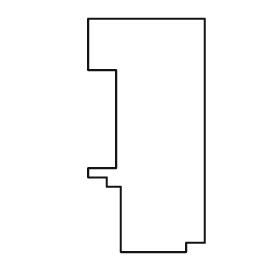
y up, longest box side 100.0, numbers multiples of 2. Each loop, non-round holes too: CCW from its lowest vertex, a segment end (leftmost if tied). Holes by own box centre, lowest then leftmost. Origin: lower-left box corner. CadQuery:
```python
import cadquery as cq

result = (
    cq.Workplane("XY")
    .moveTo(14.0, 0.0)
    .lineTo(42.0, 0.0)
    .lineTo(42.0, 4.0)
    .lineTo(50.0, 4.0)
    .lineTo(50.0, 100.0)
    .lineTo(0.0, 100.0)
    .lineTo(0.0, 78.0)
    .lineTo(12.0, 78.0)
    .lineTo(12.0, 36.0)
    .lineTo(0.0, 36.0)
    .lineTo(0.0, 32.0)
    .lineTo(8.0, 32.0)
    .lineTo(8.0, 28.0)
    .lineTo(14.0, 28.0)
    .close()
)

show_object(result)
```